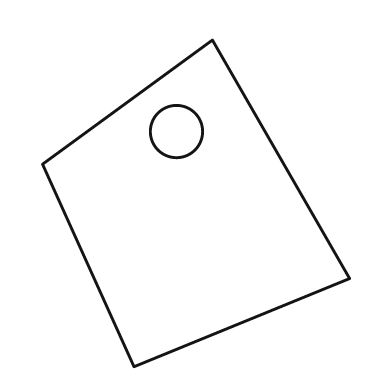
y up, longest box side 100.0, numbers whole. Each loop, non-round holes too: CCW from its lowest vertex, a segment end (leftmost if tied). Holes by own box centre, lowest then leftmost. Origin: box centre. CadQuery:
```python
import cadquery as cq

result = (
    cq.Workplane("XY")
    .moveTo(-19.0, -50.0)
    .lineTo(47.0, -23.0)
    .lineTo(5.0, 50.0)
    .lineTo(-47.0, 12.0)
    .close()
    .moveTo(-6.0, 22.0)
    .circle(8.0)
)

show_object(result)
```